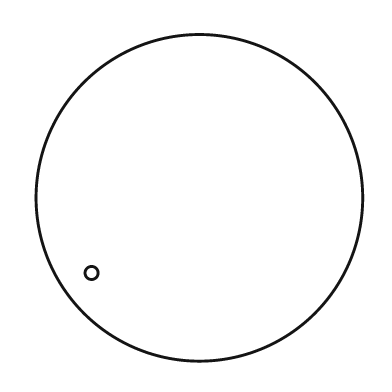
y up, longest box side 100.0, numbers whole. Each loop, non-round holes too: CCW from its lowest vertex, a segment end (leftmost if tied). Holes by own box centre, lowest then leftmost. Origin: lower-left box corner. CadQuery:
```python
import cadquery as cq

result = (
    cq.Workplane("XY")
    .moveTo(50.0, 50.0)
    .circle(50.0)
    .moveTo(17.0, 27.0)
    .circle(2.0)
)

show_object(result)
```